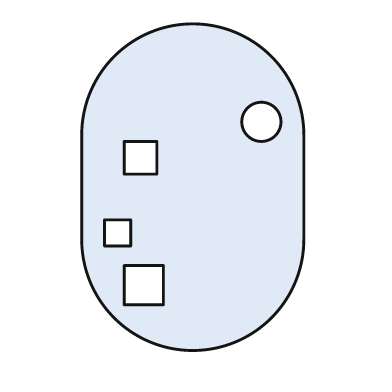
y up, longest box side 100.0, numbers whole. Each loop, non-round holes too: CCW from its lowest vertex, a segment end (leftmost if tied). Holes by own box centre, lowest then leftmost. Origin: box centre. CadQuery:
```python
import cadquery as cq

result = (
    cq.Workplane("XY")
    .moveTo(-34.0, -16.0)
    .threePointArc((0.0, -50.0), (34.0, -16.0))
    .lineTo(34.0, 16.0)
    .threePointArc((0.0, 50.0), (-34.0, 16.0))
    .close()
    .moveTo(-21.0, -36.0)
    .lineTo(-9.0, -36.0)
    .lineTo(-9.0, -24.0)
    .lineTo(-21.0, -24.0)
    .close()
    .moveTo(-27.0, -18.0)
    .lineTo(-19.0, -18.0)
    .lineTo(-19.0, -10.0)
    .lineTo(-27.0, -10.0)
    .close()
    .moveTo(-21.0, 4.0)
    .lineTo(-11.0, 4.0)
    .lineTo(-11.0, 14.0)
    .lineTo(-21.0, 14.0)
    .close()
    .moveTo(21.0, 20.0)
    .circle(6.0)
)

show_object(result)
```